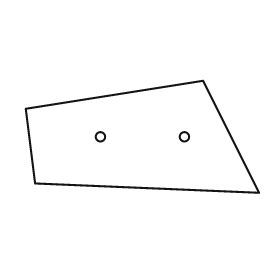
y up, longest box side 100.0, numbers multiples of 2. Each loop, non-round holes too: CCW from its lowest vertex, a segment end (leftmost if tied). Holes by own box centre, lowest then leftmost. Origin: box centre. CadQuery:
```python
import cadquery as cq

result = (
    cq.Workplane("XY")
    .moveTo(50.0, -24.0)
    .lineTo(26.0, 24.0)
    .lineTo(-50.0, 12.0)
    .lineTo(-46.0, -20.0)
    .close()
    .moveTo(-18.0, 0.0)
    .circle(2.0)
    .moveTo(18.0, 0.0)
    .circle(2.0)
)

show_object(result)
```